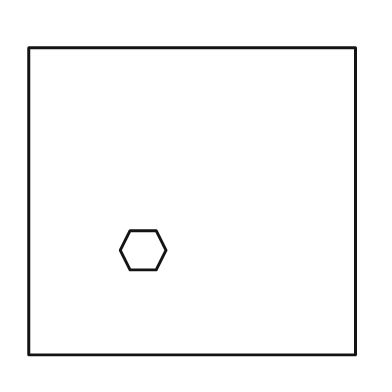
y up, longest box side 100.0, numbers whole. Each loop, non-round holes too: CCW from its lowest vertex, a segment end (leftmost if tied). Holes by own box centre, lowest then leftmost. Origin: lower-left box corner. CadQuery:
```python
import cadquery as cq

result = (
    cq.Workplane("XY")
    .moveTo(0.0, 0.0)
    .lineTo(100.0, 0.0)
    .lineTo(100.0, 94.0)
    .lineTo(0.0, 94.0)
    .close()
    .moveTo(31.0, 26.0)
    .lineTo(39.0, 26.0)
    .lineTo(42.0, 32.0)
    .lineTo(39.0, 38.0)
    .lineTo(31.0, 38.0)
    .lineTo(28.0, 32.0)
    .close()
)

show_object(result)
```